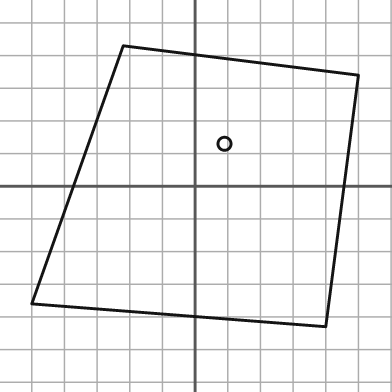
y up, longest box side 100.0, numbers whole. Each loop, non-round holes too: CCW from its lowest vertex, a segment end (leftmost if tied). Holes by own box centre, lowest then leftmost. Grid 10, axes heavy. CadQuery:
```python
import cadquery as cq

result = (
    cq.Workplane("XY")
    .moveTo(40.0, -43.0)
    .lineTo(50.0, 34.0)
    .lineTo(-22.0, 43.0)
    .lineTo(-50.0, -36.0)
    .close()
    .moveTo(9.0, 13.0)
    .circle(2.0)
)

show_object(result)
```